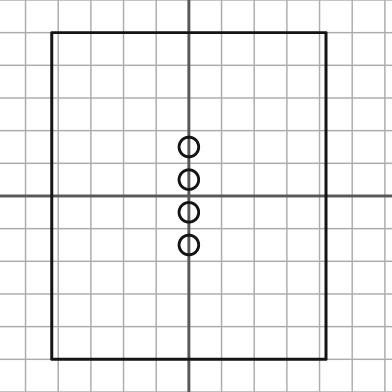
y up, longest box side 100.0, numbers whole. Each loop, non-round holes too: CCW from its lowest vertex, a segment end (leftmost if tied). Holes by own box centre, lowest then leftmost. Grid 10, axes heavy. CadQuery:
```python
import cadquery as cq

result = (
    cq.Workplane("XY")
    .moveTo(-42.0, -50.0)
    .lineTo(42.0, -50.0)
    .lineTo(42.0, 50.0)
    .lineTo(-42.0, 50.0)
    .close()
    .moveTo(0.0, -15.0)
    .circle(3.0)
    .moveTo(0.0, -5.0)
    .circle(3.0)
    .moveTo(0.0, 5.0)
    .circle(3.0)
    .moveTo(0.0, 15.0)
    .circle(3.0)
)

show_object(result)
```